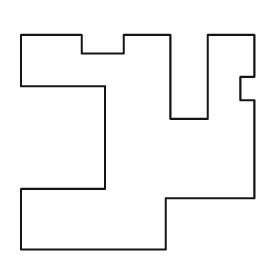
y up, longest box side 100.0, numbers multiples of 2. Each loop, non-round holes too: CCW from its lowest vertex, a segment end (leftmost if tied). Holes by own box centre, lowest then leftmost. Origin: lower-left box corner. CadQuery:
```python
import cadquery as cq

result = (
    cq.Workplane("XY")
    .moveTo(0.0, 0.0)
    .lineTo(62.0, 0.0)
    .lineTo(62.0, 22.0)
    .lineTo(100.0, 22.0)
    .lineTo(100.0, 64.0)
    .lineTo(94.0, 64.0)
    .lineTo(94.0, 74.0)
    .lineTo(100.0, 74.0)
    .lineTo(100.0, 92.0)
    .lineTo(80.0, 92.0)
    .lineTo(80.0, 56.0)
    .lineTo(64.0, 56.0)
    .lineTo(64.0, 92.0)
    .lineTo(44.0, 92.0)
    .lineTo(44.0, 84.0)
    .lineTo(26.0, 84.0)
    .lineTo(26.0, 92.0)
    .lineTo(0.0, 92.0)
    .lineTo(0.0, 70.0)
    .lineTo(36.0, 70.0)
    .lineTo(36.0, 26.0)
    .lineTo(0.0, 26.0)
    .close()
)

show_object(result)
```